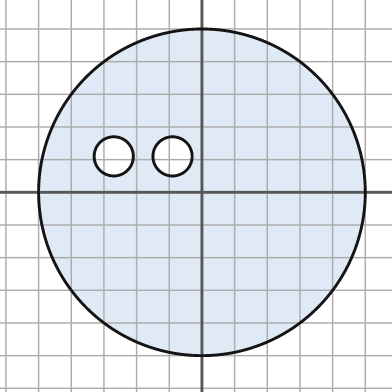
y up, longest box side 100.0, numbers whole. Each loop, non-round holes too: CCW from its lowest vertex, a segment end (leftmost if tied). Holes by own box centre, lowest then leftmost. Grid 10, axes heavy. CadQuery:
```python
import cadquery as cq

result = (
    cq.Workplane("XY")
    .moveTo(0.0, 0.0)
    .circle(50.0)
    .moveTo(-27.0, 11.0)
    .circle(6.0)
    .moveTo(-9.0, 11.0)
    .circle(6.0)
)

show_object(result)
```